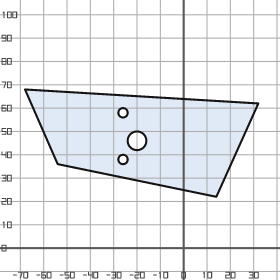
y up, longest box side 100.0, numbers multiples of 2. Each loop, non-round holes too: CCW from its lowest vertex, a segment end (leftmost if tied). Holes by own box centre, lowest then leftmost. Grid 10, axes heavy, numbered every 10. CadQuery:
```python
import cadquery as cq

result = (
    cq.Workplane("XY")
    .moveTo(14.0, 22.0)
    .lineTo(32.0, 62.0)
    .lineTo(-68.0, 68.0)
    .lineTo(-54.0, 36.0)
    .close()
    .moveTo(-26.0, 38.0)
    .circle(2.0)
    .moveTo(-20.0, 46.0)
    .circle(4.0)
    .moveTo(-26.0, 58.0)
    .circle(2.0)
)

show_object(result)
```